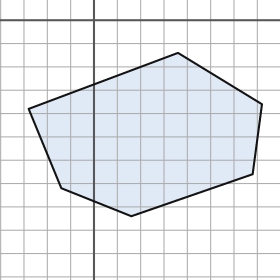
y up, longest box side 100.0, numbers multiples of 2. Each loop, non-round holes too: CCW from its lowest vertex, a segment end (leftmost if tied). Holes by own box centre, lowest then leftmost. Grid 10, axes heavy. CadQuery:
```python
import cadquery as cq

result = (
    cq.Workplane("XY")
    .moveTo(16.0, -84.0)
    .lineTo(68.0, -66.0)
    .lineTo(72.0, -36.0)
    .lineTo(36.0, -14.0)
    .lineTo(-28.0, -38.0)
    .lineTo(-14.0, -72.0)
    .close()
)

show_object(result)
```